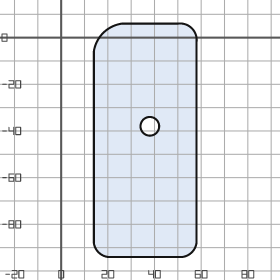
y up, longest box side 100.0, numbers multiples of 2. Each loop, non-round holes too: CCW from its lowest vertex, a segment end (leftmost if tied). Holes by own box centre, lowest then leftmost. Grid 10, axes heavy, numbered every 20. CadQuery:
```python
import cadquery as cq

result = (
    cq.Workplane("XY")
    .moveTo(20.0, -94.0)
    .lineTo(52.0, -94.0)
    .threePointArc((56.0, -92.0), (58.0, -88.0))
    .lineTo(58.0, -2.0)
    .threePointArc((56.0, 4.0), (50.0, 6.0))
    .lineTo(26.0, 6.0)
    .threePointArc((18.0, 2.0), (14.0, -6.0))
    .lineTo(14.0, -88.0)
    .threePointArc((16.0, -92.0), (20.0, -94.0))
    .close()
    .moveTo(38.0, -38.0)
    .circle(4.0)
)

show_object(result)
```